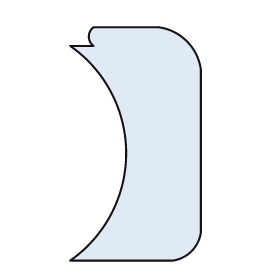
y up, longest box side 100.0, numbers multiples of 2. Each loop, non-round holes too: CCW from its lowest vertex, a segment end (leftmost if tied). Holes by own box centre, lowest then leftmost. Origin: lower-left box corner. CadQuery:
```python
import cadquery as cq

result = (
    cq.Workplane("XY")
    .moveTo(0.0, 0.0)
    .lineTo(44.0, 0.0)
    .threePointArc((52.0, 4.0), (56.0, 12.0))
    .lineTo(56.0, 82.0)
    .threePointArc((50.0, 94.0), (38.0, 100.0))
    .lineTo(10.0, 100.0)
    .threePointArc((8.0, 96.0), (10.0, 92.0))
    .lineTo(0.0, 92.0)
    .threePointArc((24.0, 46.0), (0.0, 0.0))
    .close()
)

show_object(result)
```